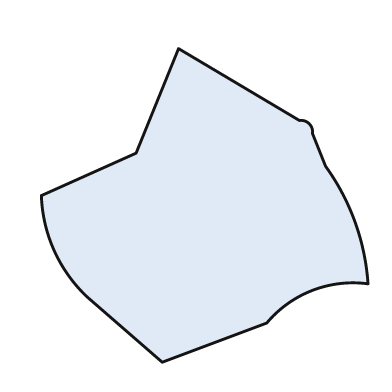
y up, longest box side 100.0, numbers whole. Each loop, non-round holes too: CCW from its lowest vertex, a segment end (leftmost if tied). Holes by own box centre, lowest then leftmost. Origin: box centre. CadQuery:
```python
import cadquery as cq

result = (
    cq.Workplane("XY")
    .moveTo(-13.0, -48.0)
    .lineTo(19.0, -36.0)
    .threePointArc((33.0, -26.0), (50.0, -24.0))
    .threePointArc((46.0, -5.0), (37.0, 12.0))
    .lineTo(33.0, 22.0)
    .threePointArc((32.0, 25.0), (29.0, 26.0))
    .lineTo(-8.0, 48.0)
    .lineTo(-21.0, 16.0)
    .lineTo(-50.0, 3.0)
    .threePointArc((-46.0, -14.0), (-36.0, -28.0))
    .close()
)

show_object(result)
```